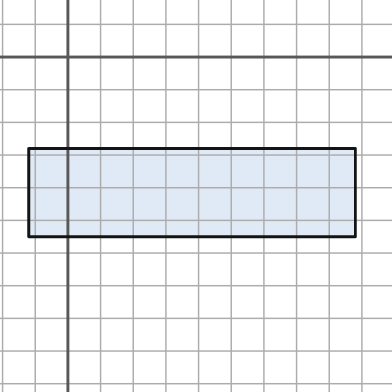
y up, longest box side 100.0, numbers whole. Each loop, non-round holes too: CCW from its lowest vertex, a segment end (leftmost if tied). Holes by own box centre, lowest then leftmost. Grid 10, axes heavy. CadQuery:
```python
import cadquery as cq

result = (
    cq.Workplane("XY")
    .moveTo(-12.0, -55.0)
    .lineTo(88.0, -55.0)
    .lineTo(88.0, -28.0)
    .lineTo(-12.0, -28.0)
    .close()
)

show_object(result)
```